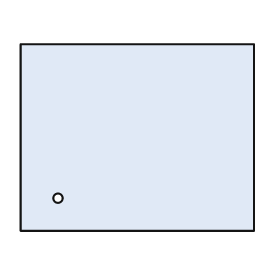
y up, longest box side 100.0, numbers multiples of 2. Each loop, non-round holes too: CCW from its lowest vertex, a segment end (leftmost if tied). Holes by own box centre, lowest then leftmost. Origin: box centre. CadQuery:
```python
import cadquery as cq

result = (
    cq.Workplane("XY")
    .moveTo(-50.0, -40.0)
    .lineTo(50.0, -40.0)
    .lineTo(50.0, 40.0)
    .lineTo(-50.0, 40.0)
    .close()
    .moveTo(-34.0, -26.0)
    .circle(2.0)
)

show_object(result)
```